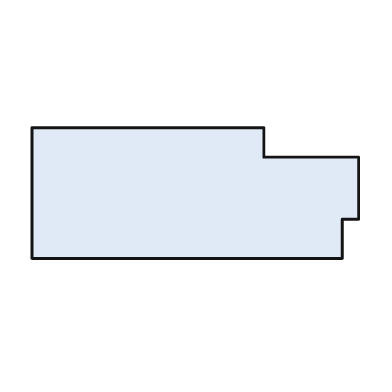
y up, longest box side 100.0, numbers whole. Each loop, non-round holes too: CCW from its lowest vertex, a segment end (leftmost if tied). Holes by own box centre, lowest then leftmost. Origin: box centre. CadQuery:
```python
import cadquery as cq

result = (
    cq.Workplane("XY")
    .moveTo(-50.0, -20.0)
    .lineTo(45.0, -20.0)
    .lineTo(45.0, -8.0)
    .lineTo(50.0, -8.0)
    .lineTo(50.0, 11.0)
    .lineTo(21.0, 11.0)
    .lineTo(21.0, 20.0)
    .lineTo(-50.0, 20.0)
    .close()
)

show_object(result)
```